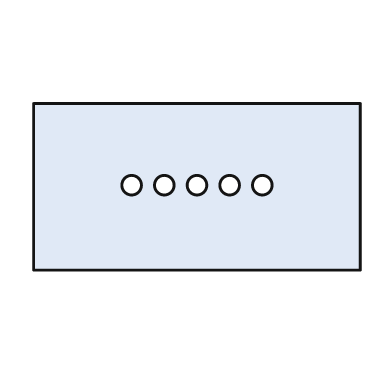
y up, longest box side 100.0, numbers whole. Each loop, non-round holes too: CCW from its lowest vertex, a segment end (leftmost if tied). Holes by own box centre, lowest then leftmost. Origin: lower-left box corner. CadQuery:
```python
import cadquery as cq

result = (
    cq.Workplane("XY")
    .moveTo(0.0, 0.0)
    .lineTo(100.0, 0.0)
    .lineTo(100.0, 51.0)
    .lineTo(0.0, 51.0)
    .close()
    .moveTo(30.0, 26.0)
    .circle(3.0)
    .moveTo(40.0, 26.0)
    .circle(3.0)
    .moveTo(50.0, 26.0)
    .circle(3.0)
    .moveTo(60.0, 26.0)
    .circle(3.0)
    .moveTo(70.0, 26.0)
    .circle(3.0)
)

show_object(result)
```